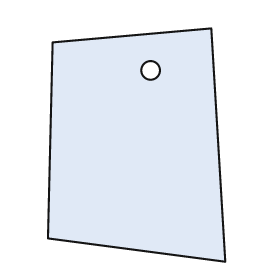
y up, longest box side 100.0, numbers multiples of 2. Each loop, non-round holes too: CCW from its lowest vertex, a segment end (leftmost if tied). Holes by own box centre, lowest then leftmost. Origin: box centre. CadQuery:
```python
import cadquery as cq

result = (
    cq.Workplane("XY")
    .moveTo(38.0, -50.0)
    .lineTo(32.0, 50.0)
    .lineTo(-36.0, 44.0)
    .lineTo(-38.0, -40.0)
    .close()
    .moveTo(6.0, 32.0)
    .circle(4.0)
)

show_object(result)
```